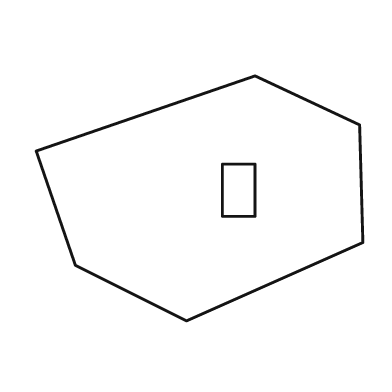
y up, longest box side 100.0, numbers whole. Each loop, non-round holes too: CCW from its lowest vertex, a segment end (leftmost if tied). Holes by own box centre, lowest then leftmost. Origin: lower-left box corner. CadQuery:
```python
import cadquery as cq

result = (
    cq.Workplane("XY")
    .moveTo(46.0, 0.0)
    .lineTo(100.0, 24.0)
    .lineTo(99.0, 60.0)
    .lineTo(67.0, 75.0)
    .lineTo(0.0, 52.0)
    .lineTo(12.0, 17.0)
    .close()
    .moveTo(57.0, 32.0)
    .lineTo(67.0, 32.0)
    .lineTo(67.0, 48.0)
    .lineTo(57.0, 48.0)
    .close()
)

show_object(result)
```